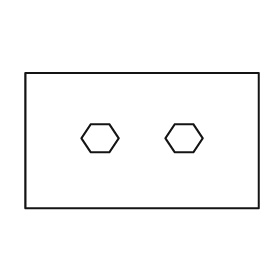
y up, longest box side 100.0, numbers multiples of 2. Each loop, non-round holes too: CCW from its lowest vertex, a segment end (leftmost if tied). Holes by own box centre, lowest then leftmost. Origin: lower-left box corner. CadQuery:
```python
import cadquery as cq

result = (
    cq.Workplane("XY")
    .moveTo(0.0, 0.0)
    .lineTo(100.0, 0.0)
    .lineTo(100.0, 58.0)
    .lineTo(0.0, 58.0)
    .close()
    .moveTo(28.0, 24.0)
    .lineTo(36.0, 24.0)
    .lineTo(40.0, 30.0)
    .lineTo(36.0, 36.0)
    .lineTo(28.0, 36.0)
    .lineTo(24.0, 30.0)
    .close()
    .moveTo(64.0, 24.0)
    .lineTo(72.0, 24.0)
    .lineTo(76.0, 30.0)
    .lineTo(72.0, 36.0)
    .lineTo(64.0, 36.0)
    .lineTo(60.0, 30.0)
    .close()
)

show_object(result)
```